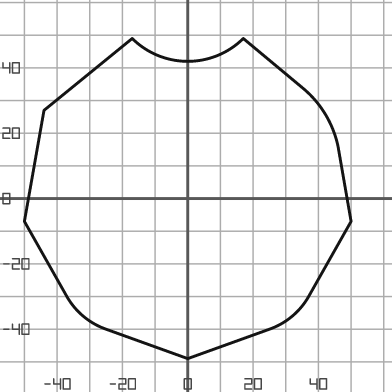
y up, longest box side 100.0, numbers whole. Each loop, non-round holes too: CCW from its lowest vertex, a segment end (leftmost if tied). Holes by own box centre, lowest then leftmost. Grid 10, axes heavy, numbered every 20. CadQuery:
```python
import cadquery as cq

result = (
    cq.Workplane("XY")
    .moveTo(0.0, -49.0)
    .lineTo(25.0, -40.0)
    .threePointArc((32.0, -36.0), (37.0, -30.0))
    .lineTo(50.0, -7.0)
    .lineTo(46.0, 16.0)
    .threePointArc((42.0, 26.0), (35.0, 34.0))
    .lineTo(17.0, 49.0)
    .threePointArc((0.0, 42.0), (-17.0, 49.0))
    .lineTo(-44.0, 27.0)
    .lineTo(-50.0, -7.0)
    .lineTo(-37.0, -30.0)
    .threePointArc((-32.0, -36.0), (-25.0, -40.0))
    .close()
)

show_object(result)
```